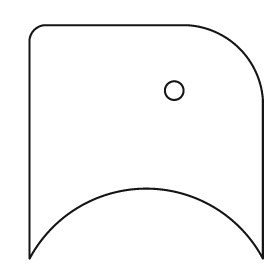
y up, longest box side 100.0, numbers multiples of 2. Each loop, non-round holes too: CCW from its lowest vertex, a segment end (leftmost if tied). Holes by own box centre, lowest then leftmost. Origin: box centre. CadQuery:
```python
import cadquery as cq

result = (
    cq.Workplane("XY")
    .moveTo(-50.0, -50.0)
    .threePointArc((0.0, -20.0), (50.0, -50.0))
    .lineTo(50.0, 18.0)
    .threePointArc((40.0, 40.0), (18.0, 50.0))
    .lineTo(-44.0, 50.0)
    .threePointArc((-48.0, 48.0), (-50.0, 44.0))
    .close()
    .moveTo(12.0, 22.0)
    .circle(4.0)
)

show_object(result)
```